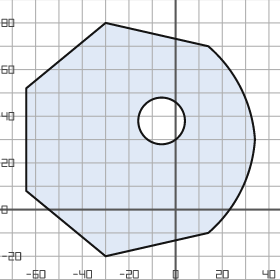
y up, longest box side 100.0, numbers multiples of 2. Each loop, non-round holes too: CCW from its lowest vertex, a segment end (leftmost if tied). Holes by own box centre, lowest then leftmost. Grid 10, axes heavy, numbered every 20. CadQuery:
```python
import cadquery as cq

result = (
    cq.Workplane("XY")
    .moveTo(-30.0, -20.0)
    .lineTo(14.0, -10.0)
    .threePointArc((28.0, 8.0), (34.0, 30.0))
    .threePointArc((28.0, 52.0), (14.0, 70.0))
    .lineTo(-30.0, 80.0)
    .lineTo(-64.0, 52.0)
    .lineTo(-64.0, 8.0)
    .close()
    .moveTo(-6.0, 38.0)
    .circle(10.0)
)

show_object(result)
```